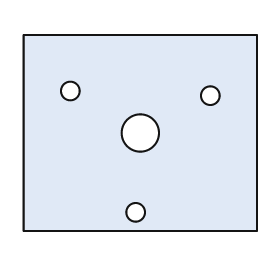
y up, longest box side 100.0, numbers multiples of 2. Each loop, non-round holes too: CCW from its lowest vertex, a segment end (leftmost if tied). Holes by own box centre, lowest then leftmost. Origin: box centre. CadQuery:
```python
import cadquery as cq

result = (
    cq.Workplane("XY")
    .moveTo(-50.0, -42.0)
    .lineTo(50.0, -42.0)
    .lineTo(50.0, 42.0)
    .lineTo(-50.0, 42.0)
    .close()
    .moveTo(-2.0, -34.0)
    .circle(4.0)
    .moveTo(0.0, 0.0)
    .circle(8.0)
    .moveTo(30.0, 16.0)
    .circle(4.0)
    .moveTo(-30.0, 18.0)
    .circle(4.0)
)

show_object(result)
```